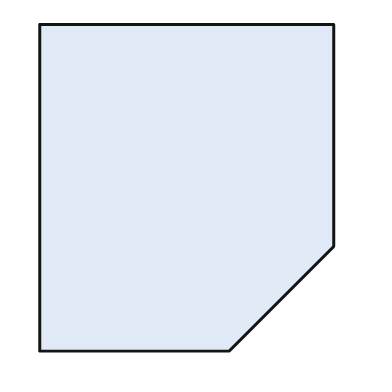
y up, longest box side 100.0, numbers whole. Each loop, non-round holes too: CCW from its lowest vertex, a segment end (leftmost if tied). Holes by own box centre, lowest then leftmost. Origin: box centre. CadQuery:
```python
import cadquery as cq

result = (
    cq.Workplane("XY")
    .moveTo(-45.0, -50.0)
    .lineTo(13.0, -50.0)
    .lineTo(45.0, -18.0)
    .lineTo(45.0, 50.0)
    .lineTo(-45.0, 50.0)
    .close()
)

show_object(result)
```